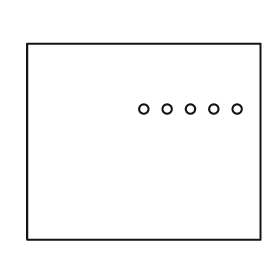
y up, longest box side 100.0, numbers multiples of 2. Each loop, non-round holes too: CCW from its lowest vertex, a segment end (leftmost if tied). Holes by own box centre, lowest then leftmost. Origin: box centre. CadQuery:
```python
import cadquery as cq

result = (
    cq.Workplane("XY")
    .moveTo(-50.0, -42.0)
    .lineTo(50.0, -42.0)
    .lineTo(50.0, 42.0)
    .lineTo(-50.0, 42.0)
    .close()
    .moveTo(0.0, 14.0)
    .circle(2.0)
    .moveTo(10.0, 14.0)
    .circle(2.0)
    .moveTo(20.0, 14.0)
    .circle(2.0)
    .moveTo(30.0, 14.0)
    .circle(2.0)
    .moveTo(40.0, 14.0)
    .circle(2.0)
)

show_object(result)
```